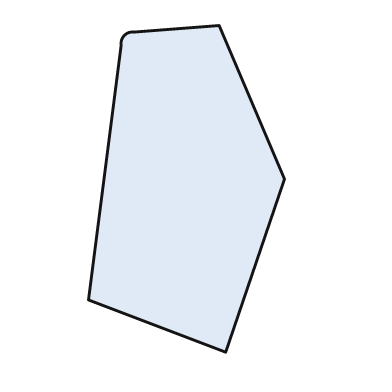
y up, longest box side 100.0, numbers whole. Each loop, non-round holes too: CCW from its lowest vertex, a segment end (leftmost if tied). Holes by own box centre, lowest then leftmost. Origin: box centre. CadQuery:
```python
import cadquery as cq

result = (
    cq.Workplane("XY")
    .moveTo(12.0, -50.0)
    .lineTo(30.0, 3.0)
    .lineTo(10.0, 50.0)
    .lineTo(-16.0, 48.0)
    .threePointArc((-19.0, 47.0), (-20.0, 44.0))
    .lineTo(-30.0, -34.0)
    .close()
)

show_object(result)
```